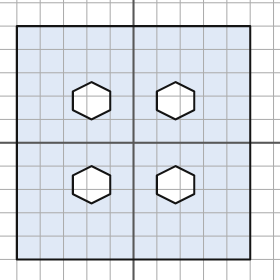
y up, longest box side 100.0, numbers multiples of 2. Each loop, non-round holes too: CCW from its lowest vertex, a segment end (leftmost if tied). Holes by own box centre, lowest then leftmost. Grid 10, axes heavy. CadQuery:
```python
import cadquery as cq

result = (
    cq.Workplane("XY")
    .moveTo(-50.0, -50.0)
    .lineTo(50.0, -50.0)
    .lineTo(50.0, 50.0)
    .lineTo(-50.0, 50.0)
    .close()
    .moveTo(-18.0, -26.0)
    .lineTo(-10.0, -22.0)
    .lineTo(-10.0, -14.0)
    .lineTo(-18.0, -10.0)
    .lineTo(-26.0, -14.0)
    .lineTo(-26.0, -22.0)
    .close()
    .moveTo(18.0, -26.0)
    .lineTo(26.0, -22.0)
    .lineTo(26.0, -14.0)
    .lineTo(18.0, -10.0)
    .lineTo(10.0, -14.0)
    .lineTo(10.0, -22.0)
    .close()
    .moveTo(-18.0, 10.0)
    .lineTo(-10.0, 14.0)
    .lineTo(-10.0, 22.0)
    .lineTo(-18.0, 26.0)
    .lineTo(-26.0, 22.0)
    .lineTo(-26.0, 14.0)
    .close()
    .moveTo(18.0, 10.0)
    .lineTo(26.0, 14.0)
    .lineTo(26.0, 22.0)
    .lineTo(18.0, 26.0)
    .lineTo(10.0, 22.0)
    .lineTo(10.0, 14.0)
    .close()
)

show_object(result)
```